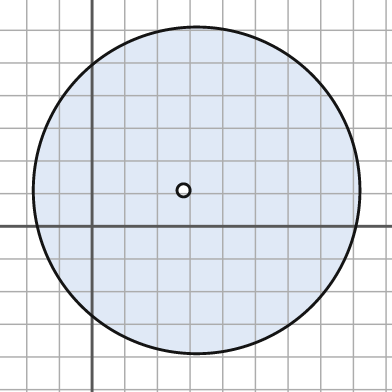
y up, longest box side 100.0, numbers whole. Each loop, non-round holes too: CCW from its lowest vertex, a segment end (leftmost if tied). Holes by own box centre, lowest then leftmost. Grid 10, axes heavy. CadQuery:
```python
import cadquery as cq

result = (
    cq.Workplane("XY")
    .moveTo(32.0, 11.0)
    .circle(50.0)
    .moveTo(28.0, 11.0)
    .circle(2.0)
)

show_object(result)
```